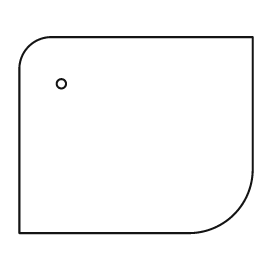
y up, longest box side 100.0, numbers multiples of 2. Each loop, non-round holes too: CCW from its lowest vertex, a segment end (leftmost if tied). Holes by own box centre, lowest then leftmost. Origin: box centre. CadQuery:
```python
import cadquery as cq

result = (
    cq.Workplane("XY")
    .moveTo(-50.0, -42.0)
    .lineTo(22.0, -42.0)
    .threePointArc((42.0, -34.0), (50.0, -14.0))
    .lineTo(50.0, 42.0)
    .lineTo(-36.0, 42.0)
    .threePointArc((-46.0, 38.0), (-50.0, 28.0))
    .close()
    .moveTo(-32.0, 22.0)
    .circle(2.0)
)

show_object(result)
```